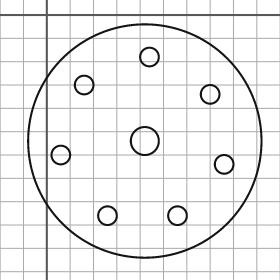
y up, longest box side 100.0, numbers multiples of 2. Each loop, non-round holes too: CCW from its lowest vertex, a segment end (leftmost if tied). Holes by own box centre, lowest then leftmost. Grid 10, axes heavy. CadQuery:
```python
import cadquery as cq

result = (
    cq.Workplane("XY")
    .moveTo(42.0, -54.0)
    .circle(50.0)
    .moveTo(26.0, -86.0)
    .circle(4.0)
    .moveTo(56.0, -86.0)
    .circle(4.0)
    .moveTo(76.0, -64.0)
    .circle(4.0)
    .moveTo(6.0, -60.0)
    .circle(4.0)
    .moveTo(42.0, -54.0)
    .circle(6.0)
    .moveTo(70.0, -34.0)
    .circle(4.0)
    .moveTo(16.0, -30.0)
    .circle(4.0)
    .moveTo(44.0, -18.0)
    .circle(4.0)
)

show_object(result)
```